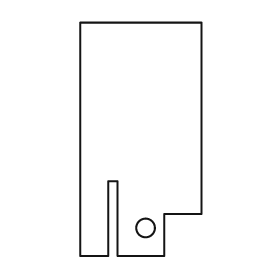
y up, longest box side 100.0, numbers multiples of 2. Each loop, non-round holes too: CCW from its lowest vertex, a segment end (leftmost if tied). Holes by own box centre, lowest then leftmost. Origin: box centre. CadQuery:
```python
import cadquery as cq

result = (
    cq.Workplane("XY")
    .moveTo(-26.0, -50.0)
    .lineTo(-14.0, -50.0)
    .lineTo(-14.0, -18.0)
    .lineTo(-10.0, -18.0)
    .lineTo(-10.0, -50.0)
    .lineTo(10.0, -50.0)
    .lineTo(10.0, -32.0)
    .lineTo(26.0, -32.0)
    .lineTo(26.0, 50.0)
    .lineTo(-26.0, 50.0)
    .close()
    .moveTo(2.0, -38.0)
    .circle(4.0)
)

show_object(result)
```